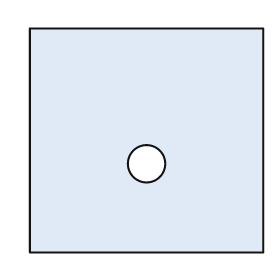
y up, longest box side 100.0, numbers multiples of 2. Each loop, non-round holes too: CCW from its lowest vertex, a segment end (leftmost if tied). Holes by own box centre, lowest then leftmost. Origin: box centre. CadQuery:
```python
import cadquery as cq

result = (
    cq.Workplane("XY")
    .moveTo(-50.0, -48.0)
    .lineTo(50.0, -48.0)
    .lineTo(50.0, 48.0)
    .lineTo(-50.0, 48.0)
    .close()
    .moveTo(0.0, -10.0)
    .circle(8.0)
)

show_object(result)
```